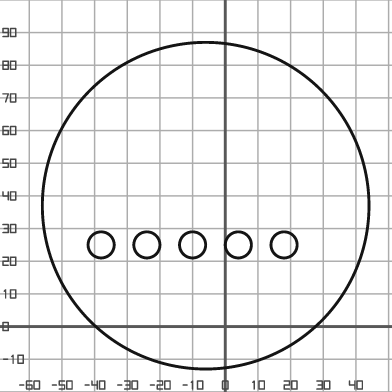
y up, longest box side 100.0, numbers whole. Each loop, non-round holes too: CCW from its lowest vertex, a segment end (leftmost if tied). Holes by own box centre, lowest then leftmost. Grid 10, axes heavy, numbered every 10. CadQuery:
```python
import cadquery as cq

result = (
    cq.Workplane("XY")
    .moveTo(-6.0, 37.0)
    .circle(50.0)
    .moveTo(-38.0, 25.0)
    .circle(4.0)
    .moveTo(-24.0, 25.0)
    .circle(4.0)
    .moveTo(-10.0, 25.0)
    .circle(4.0)
    .moveTo(4.0, 25.0)
    .circle(4.0)
    .moveTo(18.0, 25.0)
    .circle(4.0)
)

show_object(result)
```